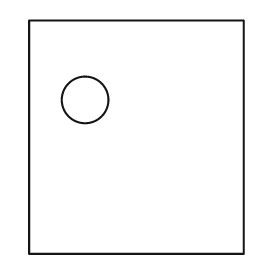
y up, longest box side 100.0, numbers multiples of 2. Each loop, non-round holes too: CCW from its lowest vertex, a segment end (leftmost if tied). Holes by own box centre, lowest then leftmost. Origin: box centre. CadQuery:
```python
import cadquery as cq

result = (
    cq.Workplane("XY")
    .moveTo(-46.0, -50.0)
    .lineTo(46.0, -50.0)
    .lineTo(46.0, 50.0)
    .lineTo(-46.0, 50.0)
    .close()
    .moveTo(-22.0, 16.0)
    .circle(10.0)
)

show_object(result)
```